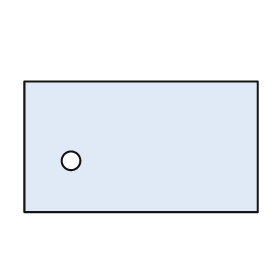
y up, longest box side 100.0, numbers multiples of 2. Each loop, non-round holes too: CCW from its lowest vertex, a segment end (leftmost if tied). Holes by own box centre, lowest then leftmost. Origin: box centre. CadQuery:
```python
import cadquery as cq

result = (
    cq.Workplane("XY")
    .moveTo(-50.0, -28.0)
    .lineTo(50.0, -28.0)
    .lineTo(50.0, 28.0)
    .lineTo(-50.0, 28.0)
    .close()
    .moveTo(-30.0, -6.0)
    .circle(4.0)
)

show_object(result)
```